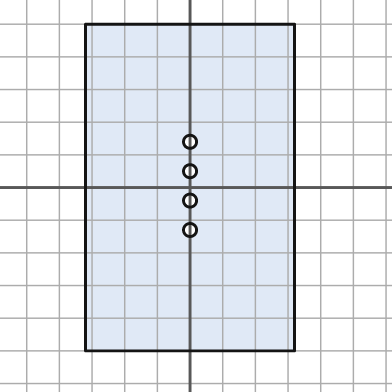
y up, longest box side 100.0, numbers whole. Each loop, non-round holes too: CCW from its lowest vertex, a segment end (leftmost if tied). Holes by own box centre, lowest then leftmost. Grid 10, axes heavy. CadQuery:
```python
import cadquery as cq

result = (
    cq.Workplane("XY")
    .moveTo(-32.0, -50.0)
    .lineTo(32.0, -50.0)
    .lineTo(32.0, 50.0)
    .lineTo(-32.0, 50.0)
    .close()
    .moveTo(0.0, -13.0)
    .circle(2.0)
    .moveTo(0.0, -4.0)
    .circle(2.0)
    .moveTo(0.0, 5.0)
    .circle(2.0)
    .moveTo(0.0, 14.0)
    .circle(2.0)
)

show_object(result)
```